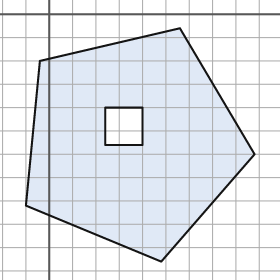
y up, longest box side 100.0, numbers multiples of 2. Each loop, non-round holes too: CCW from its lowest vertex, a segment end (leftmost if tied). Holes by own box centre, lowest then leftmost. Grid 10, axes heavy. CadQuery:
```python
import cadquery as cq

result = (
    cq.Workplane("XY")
    .moveTo(48.0, -106.0)
    .lineTo(88.0, -60.0)
    .lineTo(56.0, -6.0)
    .lineTo(-4.0, -20.0)
    .lineTo(-10.0, -82.0)
    .close()
    .moveTo(24.0, -56.0)
    .lineTo(40.0, -56.0)
    .lineTo(40.0, -40.0)
    .lineTo(24.0, -40.0)
    .close()
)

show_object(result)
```